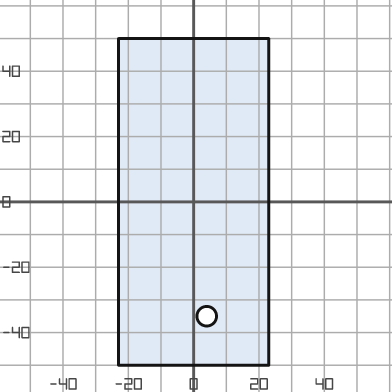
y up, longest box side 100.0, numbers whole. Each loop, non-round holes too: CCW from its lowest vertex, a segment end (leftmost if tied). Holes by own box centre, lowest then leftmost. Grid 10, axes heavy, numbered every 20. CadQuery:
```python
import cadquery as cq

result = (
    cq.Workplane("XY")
    .moveTo(-23.0, -50.0)
    .lineTo(23.0, -50.0)
    .lineTo(23.0, 50.0)
    .lineTo(-23.0, 50.0)
    .close()
    .moveTo(4.0, -35.0)
    .circle(3.0)
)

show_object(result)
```